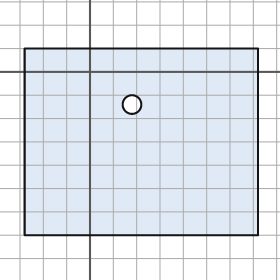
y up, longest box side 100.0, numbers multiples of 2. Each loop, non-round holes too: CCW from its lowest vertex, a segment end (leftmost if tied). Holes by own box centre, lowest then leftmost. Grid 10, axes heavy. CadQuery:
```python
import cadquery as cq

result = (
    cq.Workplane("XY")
    .moveTo(-28.0, -70.0)
    .lineTo(72.0, -70.0)
    .lineTo(72.0, 10.0)
    .lineTo(-28.0, 10.0)
    .close()
    .moveTo(18.0, -14.0)
    .circle(4.0)
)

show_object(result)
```